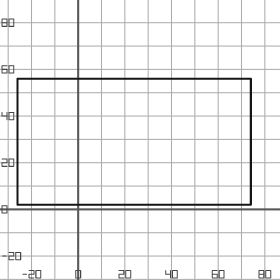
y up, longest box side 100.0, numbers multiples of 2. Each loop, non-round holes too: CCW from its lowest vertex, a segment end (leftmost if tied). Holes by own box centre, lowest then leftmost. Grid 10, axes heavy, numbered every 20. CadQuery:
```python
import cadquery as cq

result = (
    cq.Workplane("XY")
    .moveTo(-26.0, 2.0)
    .lineTo(74.0, 2.0)
    .lineTo(74.0, 56.0)
    .lineTo(-26.0, 56.0)
    .close()
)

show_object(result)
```